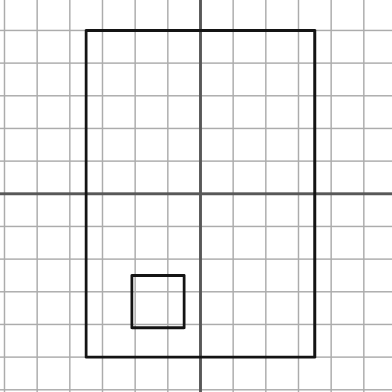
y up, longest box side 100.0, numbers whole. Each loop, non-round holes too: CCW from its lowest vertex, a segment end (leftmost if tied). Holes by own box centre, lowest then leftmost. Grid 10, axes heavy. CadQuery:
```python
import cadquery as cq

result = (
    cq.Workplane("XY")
    .moveTo(-35.0, -50.0)
    .lineTo(35.0, -50.0)
    .lineTo(35.0, 50.0)
    .lineTo(-35.0, 50.0)
    .close()
    .moveTo(-21.0, -41.0)
    .lineTo(-5.0, -41.0)
    .lineTo(-5.0, -25.0)
    .lineTo(-21.0, -25.0)
    .close()
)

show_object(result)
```